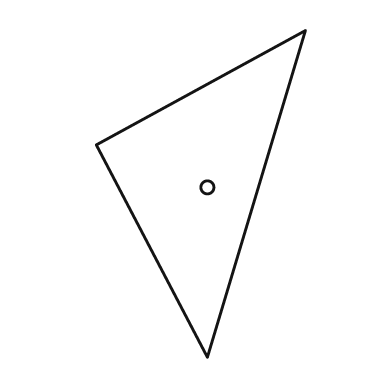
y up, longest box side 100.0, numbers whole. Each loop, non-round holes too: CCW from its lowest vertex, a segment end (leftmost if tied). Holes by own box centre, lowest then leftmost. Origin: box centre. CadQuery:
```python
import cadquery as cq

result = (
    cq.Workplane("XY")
    .moveTo(2.0, -50.0)
    .lineTo(32.0, 50.0)
    .lineTo(-32.0, 15.0)
    .close()
    .moveTo(2.0, 2.0)
    .circle(2.0)
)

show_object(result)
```